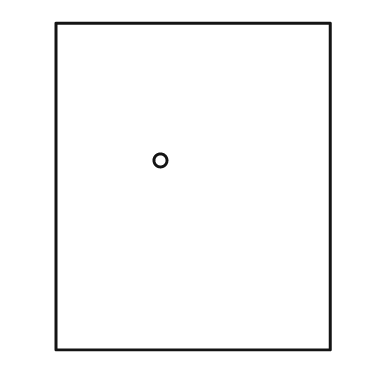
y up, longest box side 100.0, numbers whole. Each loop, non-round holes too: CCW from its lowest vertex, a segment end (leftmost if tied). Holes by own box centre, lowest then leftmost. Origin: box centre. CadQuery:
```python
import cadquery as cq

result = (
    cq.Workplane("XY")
    .moveTo(-42.0, -50.0)
    .lineTo(42.0, -50.0)
    .lineTo(42.0, 50.0)
    .lineTo(-42.0, 50.0)
    .close()
    .moveTo(-10.0, 8.0)
    .circle(2.0)
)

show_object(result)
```